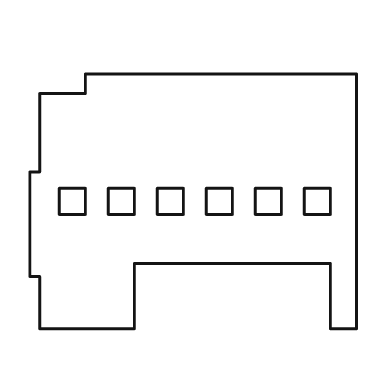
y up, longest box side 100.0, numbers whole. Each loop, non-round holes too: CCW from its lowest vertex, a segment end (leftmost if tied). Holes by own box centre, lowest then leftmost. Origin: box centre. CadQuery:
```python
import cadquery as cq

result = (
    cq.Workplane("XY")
    .moveTo(-47.0, -39.0)
    .lineTo(-18.0, -39.0)
    .lineTo(-18.0, -19.0)
    .lineTo(42.0, -19.0)
    .lineTo(42.0, -39.0)
    .lineTo(50.0, -39.0)
    .lineTo(50.0, 39.0)
    .lineTo(-33.0, 39.0)
    .lineTo(-33.0, 33.0)
    .lineTo(-47.0, 33.0)
    .lineTo(-47.0, 9.0)
    .lineTo(-50.0, 9.0)
    .lineTo(-50.0, -23.0)
    .lineTo(-47.0, -23.0)
    .close()
    .moveTo(-41.0, -4.0)
    .lineTo(-33.0, -4.0)
    .lineTo(-33.0, 4.0)
    .lineTo(-41.0, 4.0)
    .close()
    .moveTo(-26.0, -4.0)
    .lineTo(-18.0, -4.0)
    .lineTo(-18.0, 4.0)
    .lineTo(-26.0, 4.0)
    .close()
    .moveTo(-11.0, -4.0)
    .lineTo(-3.0, -4.0)
    .lineTo(-3.0, 4.0)
    .lineTo(-11.0, 4.0)
    .close()
    .moveTo(4.0, -4.0)
    .lineTo(12.0, -4.0)
    .lineTo(12.0, 4.0)
    .lineTo(4.0, 4.0)
    .close()
    .moveTo(19.0, -4.0)
    .lineTo(27.0, -4.0)
    .lineTo(27.0, 4.0)
    .lineTo(19.0, 4.0)
    .close()
    .moveTo(34.0, -4.0)
    .lineTo(42.0, -4.0)
    .lineTo(42.0, 4.0)
    .lineTo(34.0, 4.0)
    .close()
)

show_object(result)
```